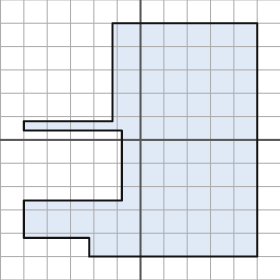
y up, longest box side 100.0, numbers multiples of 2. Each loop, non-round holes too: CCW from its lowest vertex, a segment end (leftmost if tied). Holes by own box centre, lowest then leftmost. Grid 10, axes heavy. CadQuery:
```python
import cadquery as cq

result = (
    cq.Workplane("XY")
    .moveTo(-22.0, -50.0)
    .lineTo(50.0, -50.0)
    .lineTo(50.0, 50.0)
    .lineTo(-12.0, 50.0)
    .lineTo(-12.0, 8.0)
    .lineTo(-50.0, 8.0)
    .lineTo(-50.0, 4.0)
    .lineTo(-8.0, 4.0)
    .lineTo(-8.0, -26.0)
    .lineTo(-50.0, -26.0)
    .lineTo(-50.0, -42.0)
    .lineTo(-22.0, -42.0)
    .close()
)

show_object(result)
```